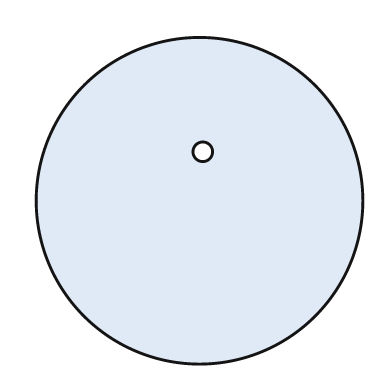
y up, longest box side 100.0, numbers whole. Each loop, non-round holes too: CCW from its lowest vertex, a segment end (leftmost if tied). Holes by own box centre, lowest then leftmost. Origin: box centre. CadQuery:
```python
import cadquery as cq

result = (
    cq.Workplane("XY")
    .moveTo(0.0, 0.0)
    .circle(50.0)
    .moveTo(1.0, 15.0)
    .circle(3.0)
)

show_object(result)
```